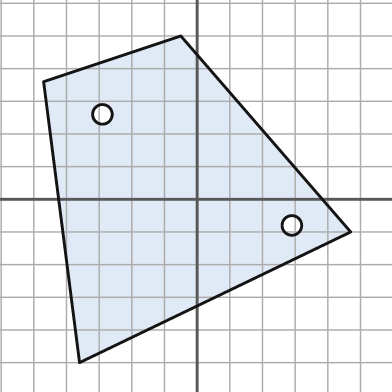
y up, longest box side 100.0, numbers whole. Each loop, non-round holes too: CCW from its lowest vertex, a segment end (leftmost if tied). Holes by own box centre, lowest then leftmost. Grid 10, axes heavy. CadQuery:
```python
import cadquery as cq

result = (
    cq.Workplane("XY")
    .moveTo(-36.0, -50.0)
    .lineTo(47.0, -10.0)
    .lineTo(-5.0, 50.0)
    .lineTo(-47.0, 36.0)
    .close()
    .moveTo(29.0, -8.0)
    .circle(3.0)
    .moveTo(-29.0, 26.0)
    .circle(3.0)
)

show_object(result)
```